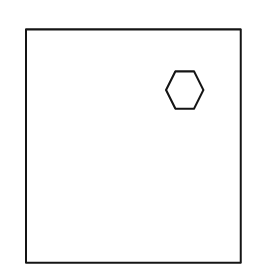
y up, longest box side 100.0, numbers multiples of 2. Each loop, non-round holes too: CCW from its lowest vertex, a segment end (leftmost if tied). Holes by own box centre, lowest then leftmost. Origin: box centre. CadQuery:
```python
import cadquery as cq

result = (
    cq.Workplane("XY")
    .moveTo(-46.0, -50.0)
    .lineTo(46.0, -50.0)
    .lineTo(46.0, 50.0)
    .lineTo(-46.0, 50.0)
    .close()
    .moveTo(18.0, 16.0)
    .lineTo(26.0, 16.0)
    .lineTo(30.0, 24.0)
    .lineTo(26.0, 32.0)
    .lineTo(18.0, 32.0)
    .lineTo(14.0, 24.0)
    .close()
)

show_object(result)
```